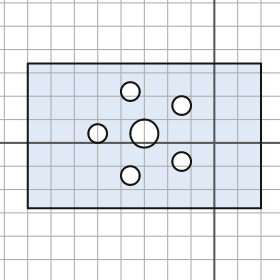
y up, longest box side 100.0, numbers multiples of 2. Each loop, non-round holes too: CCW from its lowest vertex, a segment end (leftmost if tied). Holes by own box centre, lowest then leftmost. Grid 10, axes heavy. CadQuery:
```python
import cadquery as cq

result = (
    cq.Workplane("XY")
    .moveTo(-80.0, -28.0)
    .lineTo(20.0, -28.0)
    .lineTo(20.0, 34.0)
    .lineTo(-80.0, 34.0)
    .close()
    .moveTo(-36.0, -14.0)
    .circle(4.0)
    .moveTo(-14.0, -8.0)
    .circle(4.0)
    .moveTo(-50.0, 4.0)
    .circle(4.0)
    .moveTo(-30.0, 4.0)
    .circle(6.0)
    .moveTo(-14.0, 16.0)
    .circle(4.0)
    .moveTo(-36.0, 22.0)
    .circle(4.0)
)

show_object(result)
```